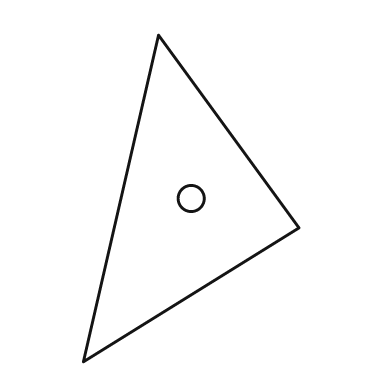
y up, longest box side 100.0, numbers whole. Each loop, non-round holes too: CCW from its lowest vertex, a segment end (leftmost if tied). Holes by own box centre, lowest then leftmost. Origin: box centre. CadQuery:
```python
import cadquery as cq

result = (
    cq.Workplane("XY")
    .moveTo(-33.0, -50.0)
    .lineTo(33.0, -9.0)
    .lineTo(-10.0, 50.0)
    .close()
    .moveTo(0.0, 0.0)
    .circle(4.0)
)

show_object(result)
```